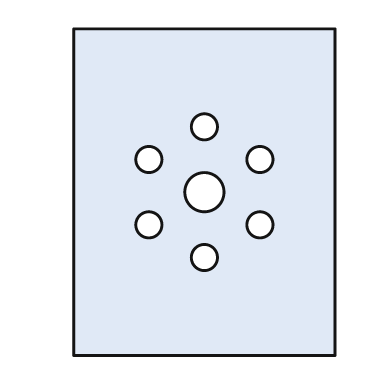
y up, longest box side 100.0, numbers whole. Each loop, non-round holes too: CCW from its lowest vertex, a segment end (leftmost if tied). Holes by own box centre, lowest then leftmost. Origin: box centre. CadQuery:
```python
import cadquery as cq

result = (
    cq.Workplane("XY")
    .moveTo(-40.0, -50.0)
    .lineTo(40.0, -50.0)
    .lineTo(40.0, 50.0)
    .lineTo(-40.0, 50.0)
    .close()
    .moveTo(0.0, -20.0)
    .circle(4.0)
    .moveTo(-17.0, -10.0)
    .circle(4.0)
    .moveTo(17.0, -10.0)
    .circle(4.0)
    .moveTo(0.0, 0.0)
    .circle(6.0)
    .moveTo(-17.0, 10.0)
    .circle(4.0)
    .moveTo(17.0, 10.0)
    .circle(4.0)
    .moveTo(0.0, 20.0)
    .circle(4.0)
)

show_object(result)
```